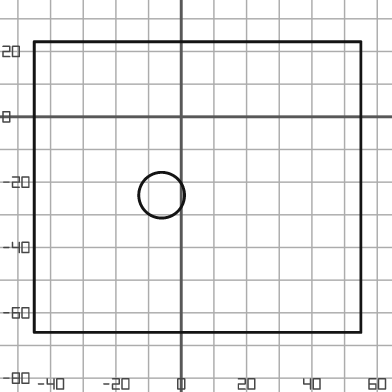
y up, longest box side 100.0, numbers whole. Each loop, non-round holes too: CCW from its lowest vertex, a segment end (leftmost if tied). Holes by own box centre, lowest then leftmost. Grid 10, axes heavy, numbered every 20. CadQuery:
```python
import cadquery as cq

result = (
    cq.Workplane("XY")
    .moveTo(-45.0, -66.0)
    .lineTo(55.0, -66.0)
    .lineTo(55.0, 23.0)
    .lineTo(-45.0, 23.0)
    .close()
    .moveTo(-6.0, -24.0)
    .circle(7.0)
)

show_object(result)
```